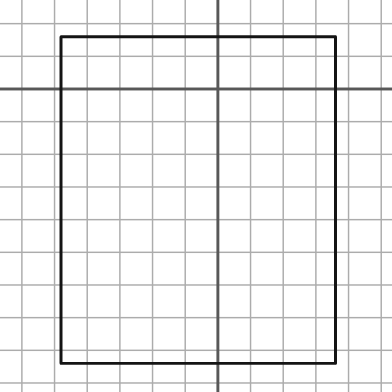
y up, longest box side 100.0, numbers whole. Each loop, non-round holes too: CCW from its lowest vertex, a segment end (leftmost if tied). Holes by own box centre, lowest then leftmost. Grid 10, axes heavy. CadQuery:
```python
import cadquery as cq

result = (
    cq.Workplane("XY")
    .moveTo(-48.0, -84.0)
    .lineTo(36.0, -84.0)
    .lineTo(36.0, 16.0)
    .lineTo(-48.0, 16.0)
    .close()
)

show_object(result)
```